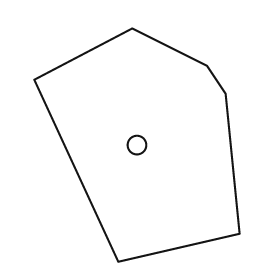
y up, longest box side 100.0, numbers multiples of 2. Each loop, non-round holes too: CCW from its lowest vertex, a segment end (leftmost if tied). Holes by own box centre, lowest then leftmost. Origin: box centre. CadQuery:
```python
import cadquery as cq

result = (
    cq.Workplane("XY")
    .moveTo(-8.0, -50.0)
    .lineTo(44.0, -38.0)
    .lineTo(38.0, 22.0)
    .lineTo(30.0, 34.0)
    .lineTo(-2.0, 50.0)
    .lineTo(-44.0, 28.0)
    .close()
    .moveTo(0.0, 0.0)
    .circle(4.0)
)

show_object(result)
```